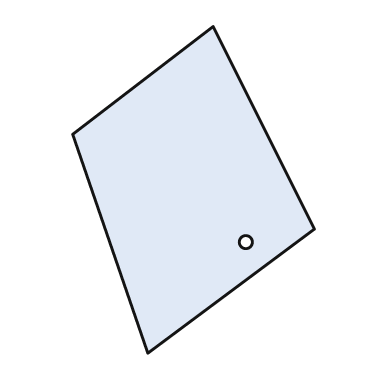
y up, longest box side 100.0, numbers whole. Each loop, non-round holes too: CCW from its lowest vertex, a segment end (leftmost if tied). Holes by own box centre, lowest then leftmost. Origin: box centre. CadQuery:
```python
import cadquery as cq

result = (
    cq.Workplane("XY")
    .moveTo(-14.0, -50.0)
    .lineTo(37.0, -12.0)
    .lineTo(6.0, 50.0)
    .lineTo(-37.0, 17.0)
    .close()
    .moveTo(16.0, -16.0)
    .circle(2.0)
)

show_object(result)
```